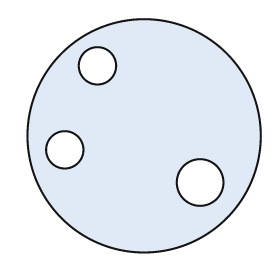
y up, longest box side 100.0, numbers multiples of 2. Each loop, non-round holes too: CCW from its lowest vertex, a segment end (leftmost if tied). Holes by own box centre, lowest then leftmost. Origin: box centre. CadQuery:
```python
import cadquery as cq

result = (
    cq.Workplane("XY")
    .moveTo(0.0, 0.0)
    .circle(50.0)
    .moveTo(24.0, -20.0)
    .circle(10.0)
    .moveTo(-34.0, -6.0)
    .circle(8.0)
    .moveTo(-20.0, 30.0)
    .circle(8.0)
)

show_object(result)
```